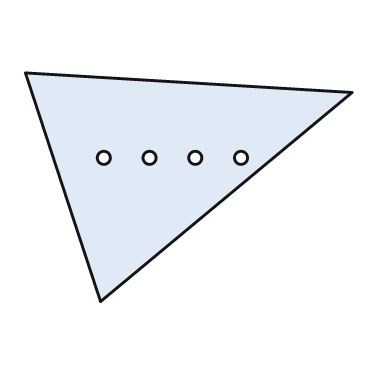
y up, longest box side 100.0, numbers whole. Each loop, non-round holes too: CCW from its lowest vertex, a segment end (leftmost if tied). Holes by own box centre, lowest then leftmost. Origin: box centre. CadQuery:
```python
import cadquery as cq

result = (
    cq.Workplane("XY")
    .moveTo(-27.0, -35.0)
    .lineTo(50.0, 29.0)
    .lineTo(-50.0, 35.0)
    .close()
    .moveTo(-26.0, 9.0)
    .circle(2.0)
    .moveTo(-12.0, 9.0)
    .circle(2.0)
    .moveTo(2.0, 9.0)
    .circle(2.0)
    .moveTo(16.0, 9.0)
    .circle(2.0)
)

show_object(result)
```